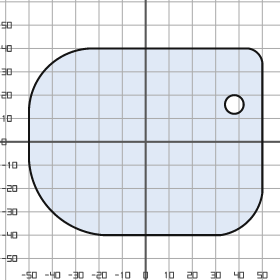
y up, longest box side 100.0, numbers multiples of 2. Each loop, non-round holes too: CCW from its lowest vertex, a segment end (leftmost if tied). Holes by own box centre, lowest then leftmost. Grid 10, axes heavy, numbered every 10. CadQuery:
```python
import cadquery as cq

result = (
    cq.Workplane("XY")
    .moveTo(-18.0, -40.0)
    .lineTo(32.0, -40.0)
    .threePointArc((44.0, -34.0), (50.0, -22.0))
    .lineTo(50.0, 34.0)
    .threePointArc((48.0, 38.0), (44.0, 40.0))
    .lineTo(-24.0, 40.0)
    .threePointArc((-42.0, 32.0), (-50.0, 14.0))
    .lineTo(-50.0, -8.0)
    .threePointArc((-40.0, -30.0), (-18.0, -40.0))
    .close()
    .moveTo(38.0, 16.0)
    .circle(4.0)
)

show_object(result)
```